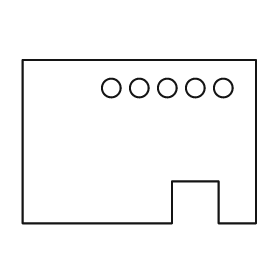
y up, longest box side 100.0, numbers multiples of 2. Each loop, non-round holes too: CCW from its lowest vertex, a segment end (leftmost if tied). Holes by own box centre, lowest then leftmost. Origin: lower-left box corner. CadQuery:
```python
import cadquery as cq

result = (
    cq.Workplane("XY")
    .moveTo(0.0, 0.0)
    .lineTo(64.0, 0.0)
    .lineTo(64.0, 18.0)
    .lineTo(84.0, 18.0)
    .lineTo(84.0, 0.0)
    .lineTo(100.0, 0.0)
    .lineTo(100.0, 70.0)
    .lineTo(0.0, 70.0)
    .close()
    .moveTo(38.0, 58.0)
    .circle(4.0)
    .moveTo(50.0, 58.0)
    .circle(4.0)
    .moveTo(62.0, 58.0)
    .circle(4.0)
    .moveTo(74.0, 58.0)
    .circle(4.0)
    .moveTo(86.0, 58.0)
    .circle(4.0)
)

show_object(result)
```